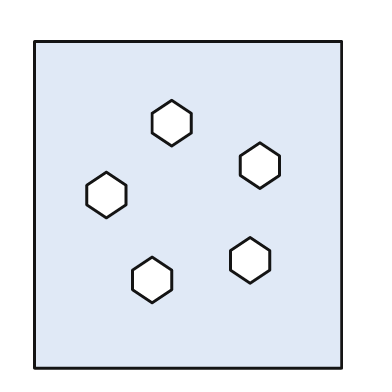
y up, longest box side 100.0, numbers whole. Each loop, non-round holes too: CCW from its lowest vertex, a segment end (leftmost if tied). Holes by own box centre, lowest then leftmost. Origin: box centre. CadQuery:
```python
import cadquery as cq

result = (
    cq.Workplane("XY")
    .moveTo(-47.0, -50.0)
    .lineTo(47.0, -50.0)
    .lineTo(47.0, 50.0)
    .lineTo(-47.0, 50.0)
    .close()
    .moveTo(-11.0, -30.0)
    .lineTo(-5.0, -26.0)
    .lineTo(-5.0, -20.0)
    .lineTo(-11.0, -16.0)
    .lineTo(-17.0, -20.0)
    .lineTo(-17.0, -26.0)
    .close()
    .moveTo(19.0, -24.0)
    .lineTo(25.0, -20.0)
    .lineTo(25.0, -14.0)
    .lineTo(19.0, -10.0)
    .lineTo(13.0, -14.0)
    .lineTo(13.0, -20.0)
    .close()
    .moveTo(-25.0, -4.0)
    .lineTo(-19.0, 0.0)
    .lineTo(-19.0, 6.0)
    .lineTo(-25.0, 10.0)
    .lineTo(-31.0, 6.0)
    .lineTo(-31.0, 0.0)
    .close()
    .moveTo(22.0, 5.0)
    .lineTo(28.0, 9.0)
    .lineTo(28.0, 15.0)
    .lineTo(22.0, 19.0)
    .lineTo(16.0, 15.0)
    .lineTo(16.0, 9.0)
    .close()
    .moveTo(-5.0, 18.0)
    .lineTo(1.0, 22.0)
    .lineTo(1.0, 28.0)
    .lineTo(-5.0, 32.0)
    .lineTo(-11.0, 28.0)
    .lineTo(-11.0, 22.0)
    .close()
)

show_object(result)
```